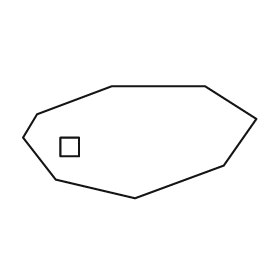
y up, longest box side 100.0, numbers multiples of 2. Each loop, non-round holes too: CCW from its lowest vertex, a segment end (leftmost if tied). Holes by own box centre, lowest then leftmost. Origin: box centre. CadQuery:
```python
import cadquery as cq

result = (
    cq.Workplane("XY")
    .moveTo(-2.0, -24.0)
    .lineTo(36.0, -10.0)
    .lineTo(50.0, 10.0)
    .lineTo(28.0, 24.0)
    .lineTo(-12.0, 24.0)
    .lineTo(-44.0, 12.0)
    .lineTo(-50.0, 2.0)
    .lineTo(-36.0, -16.0)
    .close()
    .moveTo(-34.0, -6.0)
    .lineTo(-26.0, -6.0)
    .lineTo(-26.0, 2.0)
    .lineTo(-34.0, 2.0)
    .close()
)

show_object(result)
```